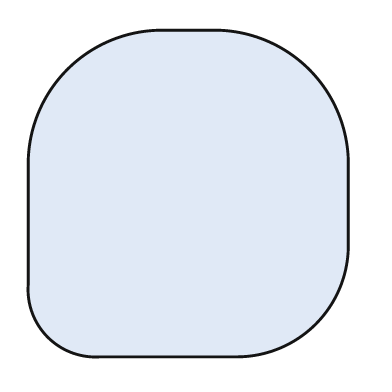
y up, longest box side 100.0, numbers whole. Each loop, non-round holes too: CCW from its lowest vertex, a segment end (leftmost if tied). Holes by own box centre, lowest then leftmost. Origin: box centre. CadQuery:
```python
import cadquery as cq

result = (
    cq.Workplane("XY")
    .moveTo(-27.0, -50.0)
    .lineTo(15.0, -50.0)
    .threePointArc((39.0, -40.0), (49.0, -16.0))
    .lineTo(49.0, 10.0)
    .threePointArc((37.0, 38.0), (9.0, 50.0))
    .lineTo(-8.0, 50.0)
    .threePointArc((-37.0, 38.0), (-49.0, 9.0))
    .lineTo(-49.0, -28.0)
    .threePointArc((-43.0, -44.0), (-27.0, -50.0))
    .close()
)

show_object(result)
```